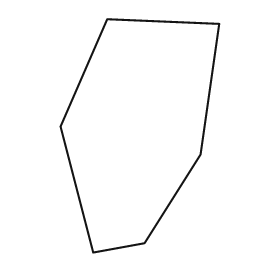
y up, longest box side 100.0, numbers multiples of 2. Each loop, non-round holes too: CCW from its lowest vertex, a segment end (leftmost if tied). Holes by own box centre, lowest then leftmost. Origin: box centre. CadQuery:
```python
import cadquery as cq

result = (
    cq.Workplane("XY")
    .moveTo(-20.0, -50.0)
    .lineTo(2.0, -46.0)
    .lineTo(26.0, -8.0)
    .lineTo(34.0, 48.0)
    .lineTo(-14.0, 50.0)
    .lineTo(-34.0, 4.0)
    .close()
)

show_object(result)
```